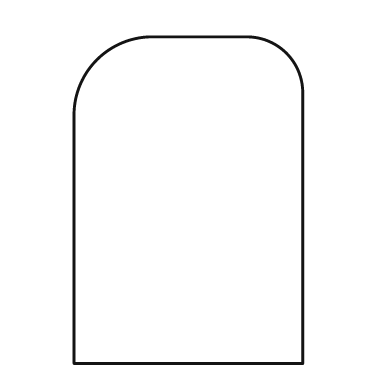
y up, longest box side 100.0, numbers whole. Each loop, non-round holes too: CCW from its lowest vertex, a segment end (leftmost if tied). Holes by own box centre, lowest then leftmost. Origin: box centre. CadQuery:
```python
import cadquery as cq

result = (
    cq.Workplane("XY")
    .moveTo(-35.0, -50.0)
    .lineTo(35.0, -50.0)
    .lineTo(35.0, 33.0)
    .threePointArc((30.0, 45.0), (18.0, 50.0))
    .lineTo(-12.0, 50.0)
    .threePointArc((-28.0, 43.0), (-35.0, 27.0))
    .close()
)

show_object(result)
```